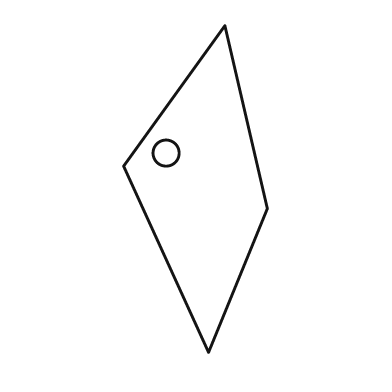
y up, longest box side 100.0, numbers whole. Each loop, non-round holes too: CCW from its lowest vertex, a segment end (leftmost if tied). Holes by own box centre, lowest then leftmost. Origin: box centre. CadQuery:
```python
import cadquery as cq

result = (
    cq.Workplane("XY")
    .moveTo(4.0, -50.0)
    .lineTo(22.0, -6.0)
    .lineTo(9.0, 50.0)
    .lineTo(-22.0, 7.0)
    .close()
    .moveTo(-9.0, 11.0)
    .circle(4.0)
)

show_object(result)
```